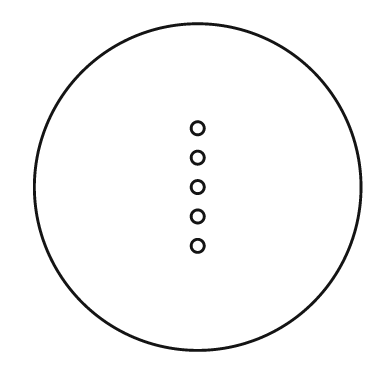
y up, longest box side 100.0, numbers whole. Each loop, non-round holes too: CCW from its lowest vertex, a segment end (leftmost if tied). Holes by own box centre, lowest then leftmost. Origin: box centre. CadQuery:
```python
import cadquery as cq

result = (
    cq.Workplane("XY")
    .moveTo(0.0, 0.0)
    .circle(50.0)
    .moveTo(0.0, -18.0)
    .circle(2.0)
    .moveTo(0.0, -9.0)
    .circle(2.0)
    .moveTo(0.0, 0.0)
    .circle(2.0)
    .moveTo(0.0, 9.0)
    .circle(2.0)
    .moveTo(0.0, 18.0)
    .circle(2.0)
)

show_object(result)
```